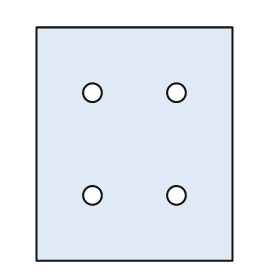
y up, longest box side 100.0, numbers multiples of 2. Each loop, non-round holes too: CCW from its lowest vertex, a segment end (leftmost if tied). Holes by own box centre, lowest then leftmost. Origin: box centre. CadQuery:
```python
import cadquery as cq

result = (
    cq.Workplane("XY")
    .moveTo(-42.0, -50.0)
    .lineTo(42.0, -50.0)
    .lineTo(42.0, 50.0)
    .lineTo(-42.0, 50.0)
    .close()
    .moveTo(-18.0, -22.0)
    .circle(4.0)
    .moveTo(18.0, -22.0)
    .circle(4.0)
    .moveTo(-18.0, 22.0)
    .circle(4.0)
    .moveTo(18.0, 22.0)
    .circle(4.0)
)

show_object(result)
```